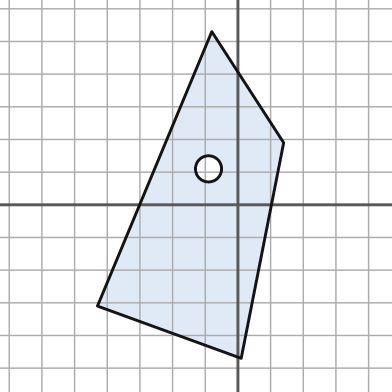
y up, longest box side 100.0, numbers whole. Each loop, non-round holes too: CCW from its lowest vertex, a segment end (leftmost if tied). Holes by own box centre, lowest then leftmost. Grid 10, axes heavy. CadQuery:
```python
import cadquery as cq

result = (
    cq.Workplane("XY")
    .moveTo(1.0, -47.0)
    .lineTo(14.0, 19.0)
    .lineTo(-8.0, 53.0)
    .lineTo(-43.0, -31.0)
    .close()
    .moveTo(-9.0, 11.0)
    .circle(4.0)
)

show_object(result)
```